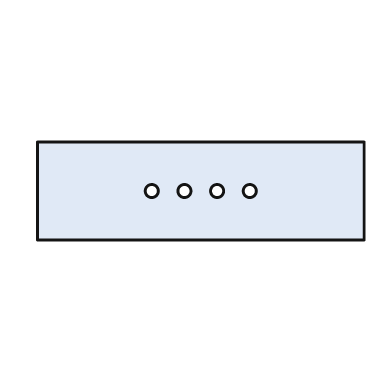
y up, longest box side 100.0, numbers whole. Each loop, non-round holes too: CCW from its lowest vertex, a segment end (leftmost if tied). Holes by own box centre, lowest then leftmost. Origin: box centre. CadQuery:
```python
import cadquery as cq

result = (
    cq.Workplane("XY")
    .moveTo(-50.0, -15.0)
    .lineTo(50.0, -15.0)
    .lineTo(50.0, 15.0)
    .lineTo(-50.0, 15.0)
    .close()
    .moveTo(-15.0, 0.0)
    .circle(2.0)
    .moveTo(-5.0, 0.0)
    .circle(2.0)
    .moveTo(5.0, 0.0)
    .circle(2.0)
    .moveTo(15.0, 0.0)
    .circle(2.0)
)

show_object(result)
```